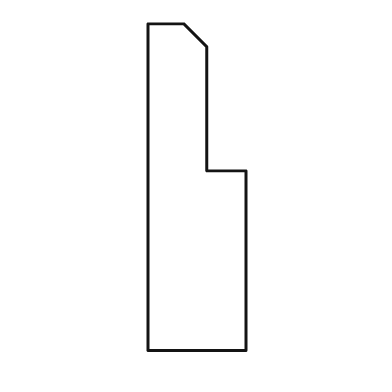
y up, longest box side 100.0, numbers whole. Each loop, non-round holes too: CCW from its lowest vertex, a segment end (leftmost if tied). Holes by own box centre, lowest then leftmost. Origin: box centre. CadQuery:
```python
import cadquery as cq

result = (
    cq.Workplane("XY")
    .moveTo(-15.0, -50.0)
    .lineTo(15.0, -50.0)
    .lineTo(15.0, 5.0)
    .lineTo(3.0, 5.0)
    .lineTo(3.0, 43.0)
    .lineTo(-4.0, 50.0)
    .lineTo(-15.0, 50.0)
    .close()
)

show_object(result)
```